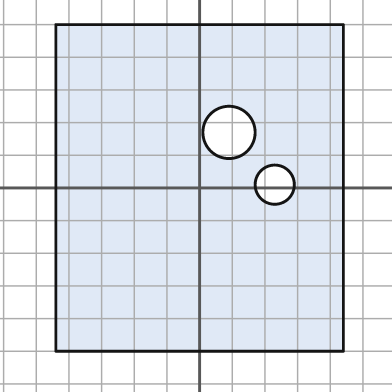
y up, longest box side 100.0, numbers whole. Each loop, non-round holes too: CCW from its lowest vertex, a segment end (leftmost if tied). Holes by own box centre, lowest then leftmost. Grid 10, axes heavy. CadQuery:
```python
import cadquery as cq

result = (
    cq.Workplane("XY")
    .moveTo(-44.0, -50.0)
    .lineTo(44.0, -50.0)
    .lineTo(44.0, 50.0)
    .lineTo(-44.0, 50.0)
    .close()
    .moveTo(23.0, 1.0)
    .circle(6.0)
    .moveTo(9.0, 17.0)
    .circle(8.0)
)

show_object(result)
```